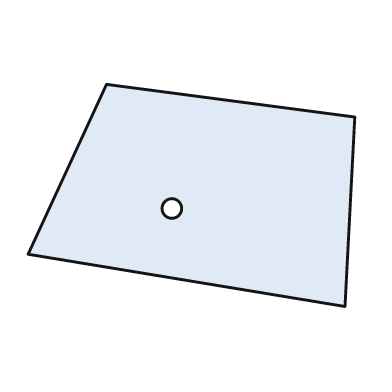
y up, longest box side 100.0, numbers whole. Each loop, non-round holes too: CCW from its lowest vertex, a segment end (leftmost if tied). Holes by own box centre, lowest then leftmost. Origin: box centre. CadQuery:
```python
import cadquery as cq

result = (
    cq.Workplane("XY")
    .moveTo(47.0, -34.0)
    .lineTo(50.0, 24.0)
    .lineTo(-26.0, 34.0)
    .lineTo(-50.0, -18.0)
    .close()
    .moveTo(-6.0, -4.0)
    .circle(3.0)
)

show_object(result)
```